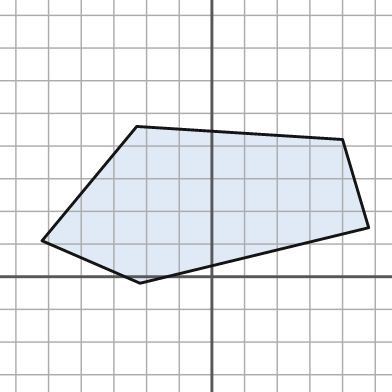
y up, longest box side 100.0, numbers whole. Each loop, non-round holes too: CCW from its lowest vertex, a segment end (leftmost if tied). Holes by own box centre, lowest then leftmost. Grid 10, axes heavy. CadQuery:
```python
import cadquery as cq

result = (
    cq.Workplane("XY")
    .moveTo(-22.0, -2.0)
    .lineTo(48.0, 15.0)
    .lineTo(40.0, 42.0)
    .lineTo(-23.0, 46.0)
    .lineTo(-52.0, 11.0)
    .close()
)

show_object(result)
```